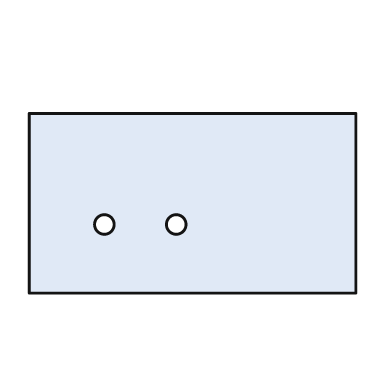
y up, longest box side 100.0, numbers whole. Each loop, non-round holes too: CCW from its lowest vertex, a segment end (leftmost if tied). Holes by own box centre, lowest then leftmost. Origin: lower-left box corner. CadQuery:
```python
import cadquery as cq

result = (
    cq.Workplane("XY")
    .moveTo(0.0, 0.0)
    .lineTo(100.0, 0.0)
    .lineTo(100.0, 55.0)
    .lineTo(0.0, 55.0)
    .close()
    .moveTo(23.0, 21.0)
    .circle(3.0)
    .moveTo(45.0, 21.0)
    .circle(3.0)
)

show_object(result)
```